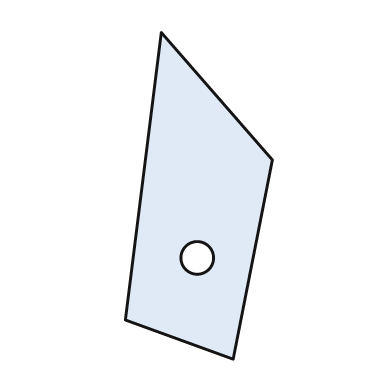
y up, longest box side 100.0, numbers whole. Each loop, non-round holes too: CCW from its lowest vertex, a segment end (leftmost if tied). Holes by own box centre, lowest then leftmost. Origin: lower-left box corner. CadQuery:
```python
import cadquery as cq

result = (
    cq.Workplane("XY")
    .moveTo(33.0, 0.0)
    .lineTo(45.0, 61.0)
    .lineTo(11.0, 100.0)
    .lineTo(0.0, 12.0)
    .close()
    .moveTo(22.0, 31.0)
    .circle(5.0)
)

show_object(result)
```